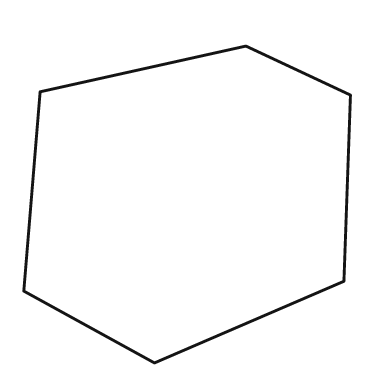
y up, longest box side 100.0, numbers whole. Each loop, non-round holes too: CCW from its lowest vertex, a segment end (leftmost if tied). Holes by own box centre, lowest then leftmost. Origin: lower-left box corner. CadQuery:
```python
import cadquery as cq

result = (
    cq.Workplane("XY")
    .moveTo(40.0, 0.0)
    .lineTo(98.0, 25.0)
    .lineTo(100.0, 82.0)
    .lineTo(68.0, 97.0)
    .lineTo(5.0, 83.0)
    .lineTo(0.0, 22.0)
    .close()
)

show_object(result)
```